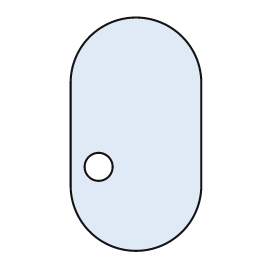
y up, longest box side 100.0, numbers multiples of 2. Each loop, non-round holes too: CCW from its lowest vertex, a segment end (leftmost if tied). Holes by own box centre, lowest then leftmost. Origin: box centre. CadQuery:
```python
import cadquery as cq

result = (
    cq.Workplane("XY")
    .moveTo(-28.0, -22.0)
    .threePointArc((0.0, -50.0), (28.0, -22.0))
    .lineTo(28.0, 22.0)
    .threePointArc((0.0, 50.0), (-28.0, 22.0))
    .close()
    .moveTo(-16.0, -14.0)
    .circle(6.0)
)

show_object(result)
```